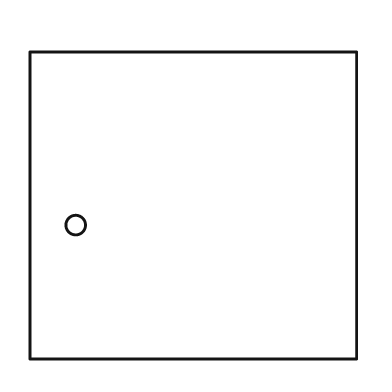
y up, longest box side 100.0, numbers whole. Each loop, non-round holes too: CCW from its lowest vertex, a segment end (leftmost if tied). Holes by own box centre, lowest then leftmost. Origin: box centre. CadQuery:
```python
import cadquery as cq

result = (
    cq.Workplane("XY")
    .moveTo(-50.0, -47.0)
    .lineTo(50.0, -47.0)
    .lineTo(50.0, 47.0)
    .lineTo(-50.0, 47.0)
    .close()
    .moveTo(-36.0, -6.0)
    .circle(3.0)
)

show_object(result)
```